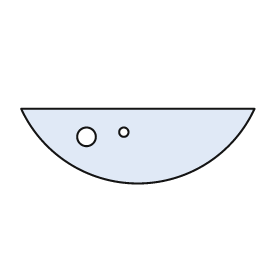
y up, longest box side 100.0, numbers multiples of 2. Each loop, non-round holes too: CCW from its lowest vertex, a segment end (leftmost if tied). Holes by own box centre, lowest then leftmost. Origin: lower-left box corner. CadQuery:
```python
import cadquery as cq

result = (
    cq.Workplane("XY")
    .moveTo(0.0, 32.0)
    .threePointArc((50.0, 0.0), (100.0, 32.0))
    .close()
    .moveTo(28.0, 20.0)
    .circle(4.0)
    .moveTo(44.0, 22.0)
    .circle(2.0)
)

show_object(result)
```